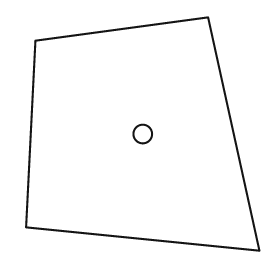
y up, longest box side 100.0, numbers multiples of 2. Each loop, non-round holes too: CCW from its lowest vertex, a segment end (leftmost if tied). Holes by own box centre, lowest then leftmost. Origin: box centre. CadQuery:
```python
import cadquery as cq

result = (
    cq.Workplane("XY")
    .moveTo(50.0, -50.0)
    .lineTo(28.0, 50.0)
    .lineTo(-46.0, 40.0)
    .lineTo(-50.0, -40.0)
    .close()
    .moveTo(0.0, 0.0)
    .circle(4.0)
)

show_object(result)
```